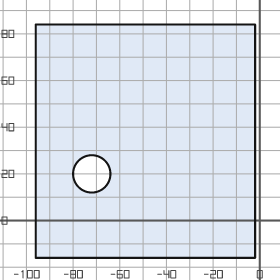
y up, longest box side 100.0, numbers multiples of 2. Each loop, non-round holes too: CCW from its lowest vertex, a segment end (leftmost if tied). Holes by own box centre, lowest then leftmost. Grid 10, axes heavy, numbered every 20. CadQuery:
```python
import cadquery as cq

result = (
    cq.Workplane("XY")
    .moveTo(-96.0, -16.0)
    .lineTo(-2.0, -16.0)
    .lineTo(-2.0, 84.0)
    .lineTo(-96.0, 84.0)
    .close()
    .moveTo(-72.0, 20.0)
    .circle(8.0)
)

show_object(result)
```